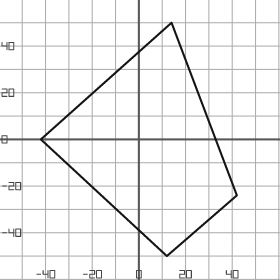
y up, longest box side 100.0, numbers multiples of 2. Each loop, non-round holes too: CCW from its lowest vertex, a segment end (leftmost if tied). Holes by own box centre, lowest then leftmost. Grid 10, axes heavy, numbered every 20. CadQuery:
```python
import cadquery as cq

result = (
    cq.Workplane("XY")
    .moveTo(12.0, -50.0)
    .lineTo(42.0, -24.0)
    .lineTo(14.0, 50.0)
    .lineTo(-42.0, 0.0)
    .close()
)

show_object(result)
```